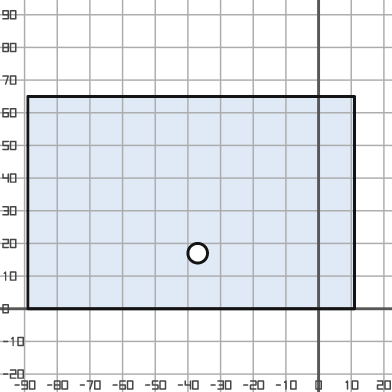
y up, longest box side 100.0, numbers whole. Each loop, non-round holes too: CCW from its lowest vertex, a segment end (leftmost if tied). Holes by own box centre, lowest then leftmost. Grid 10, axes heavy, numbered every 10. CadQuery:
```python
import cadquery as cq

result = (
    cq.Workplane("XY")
    .moveTo(-89.0, 0.0)
    .lineTo(11.0, 0.0)
    .lineTo(11.0, 65.0)
    .lineTo(-89.0, 65.0)
    .close()
    .moveTo(-37.0, 17.0)
    .circle(3.0)
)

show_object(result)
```